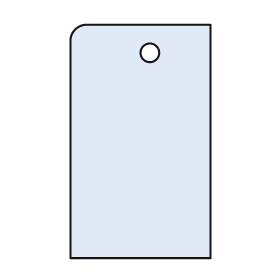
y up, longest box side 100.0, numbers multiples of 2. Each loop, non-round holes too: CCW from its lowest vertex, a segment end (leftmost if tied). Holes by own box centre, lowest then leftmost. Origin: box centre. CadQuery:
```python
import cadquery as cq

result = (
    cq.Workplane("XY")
    .moveTo(-30.0, -50.0)
    .lineTo(30.0, -50.0)
    .lineTo(30.0, 50.0)
    .lineTo(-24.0, 50.0)
    .threePointArc((-28.0, 48.0), (-30.0, 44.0))
    .close()
    .moveTo(4.0, 38.0)
    .circle(4.0)
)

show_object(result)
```